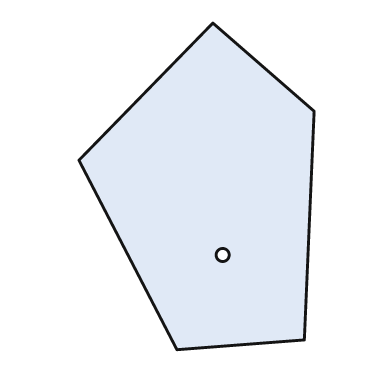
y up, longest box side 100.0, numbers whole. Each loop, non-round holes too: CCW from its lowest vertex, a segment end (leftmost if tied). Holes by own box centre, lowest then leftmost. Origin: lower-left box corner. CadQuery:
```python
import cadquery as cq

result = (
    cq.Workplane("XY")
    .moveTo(30.0, 0.0)
    .lineTo(69.0, 3.0)
    .lineTo(72.0, 73.0)
    .lineTo(41.0, 100.0)
    .lineTo(0.0, 58.0)
    .close()
    .moveTo(44.0, 29.0)
    .circle(2.0)
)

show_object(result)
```